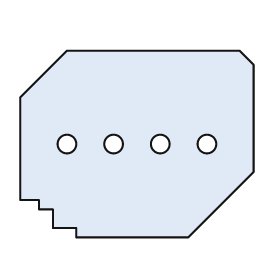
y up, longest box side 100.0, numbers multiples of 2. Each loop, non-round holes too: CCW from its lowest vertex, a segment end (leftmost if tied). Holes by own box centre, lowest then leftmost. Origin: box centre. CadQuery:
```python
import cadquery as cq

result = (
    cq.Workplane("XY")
    .moveTo(-26.0, -40.0)
    .lineTo(22.0, -40.0)
    .lineTo(50.0, -12.0)
    .lineTo(50.0, 34.0)
    .lineTo(44.0, 40.0)
    .lineTo(-30.0, 40.0)
    .lineTo(-50.0, 20.0)
    .lineTo(-50.0, -24.0)
    .lineTo(-42.0, -24.0)
    .lineTo(-42.0, -28.0)
    .lineTo(-36.0, -28.0)
    .lineTo(-36.0, -36.0)
    .lineTo(-26.0, -36.0)
    .close()
    .moveTo(-30.0, 0.0)
    .circle(4.0)
    .moveTo(-10.0, 0.0)
    .circle(4.0)
    .moveTo(10.0, 0.0)
    .circle(4.0)
    .moveTo(30.0, 0.0)
    .circle(4.0)
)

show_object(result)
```